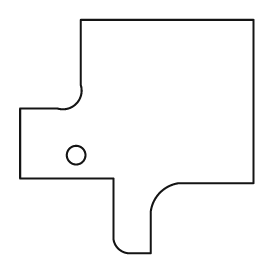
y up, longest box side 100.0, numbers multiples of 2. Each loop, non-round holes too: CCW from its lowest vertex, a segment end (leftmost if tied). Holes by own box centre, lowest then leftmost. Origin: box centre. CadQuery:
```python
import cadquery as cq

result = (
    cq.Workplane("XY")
    .moveTo(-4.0, -50.0)
    .lineTo(6.0, -50.0)
    .lineTo(6.0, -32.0)
    .threePointArc((10.0, -24.0), (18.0, -20.0))
    .lineTo(50.0, -20.0)
    .lineTo(50.0, 50.0)
    .lineTo(-24.0, 50.0)
    .lineTo(-24.0, 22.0)
    .threePointArc((-26.0, 14.0), (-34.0, 12.0))
    .lineTo(-50.0, 12.0)
    .lineTo(-50.0, -18.0)
    .lineTo(-10.0, -18.0)
    .lineTo(-10.0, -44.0)
    .threePointArc((-8.0, -48.0), (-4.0, -50.0))
    .close()
    .moveTo(-26.0, -8.0)
    .circle(4.0)
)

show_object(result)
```